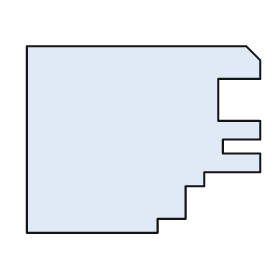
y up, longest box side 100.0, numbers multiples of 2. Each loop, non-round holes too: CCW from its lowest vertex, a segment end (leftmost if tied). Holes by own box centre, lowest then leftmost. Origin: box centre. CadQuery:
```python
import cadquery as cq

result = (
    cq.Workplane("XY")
    .moveTo(-50.0, -40.0)
    .lineTo(6.0, -40.0)
    .lineTo(6.0, -34.0)
    .lineTo(18.0, -34.0)
    .lineTo(18.0, -20.0)
    .lineTo(26.0, -20.0)
    .lineTo(26.0, -14.0)
    .lineTo(50.0, -14.0)
    .lineTo(50.0, -6.0)
    .lineTo(34.0, -6.0)
    .lineTo(34.0, 0.0)
    .lineTo(50.0, 0.0)
    .lineTo(50.0, 8.0)
    .lineTo(32.0, 8.0)
    .lineTo(32.0, 26.0)
    .lineTo(50.0, 26.0)
    .lineTo(50.0, 34.0)
    .lineTo(44.0, 40.0)
    .lineTo(-50.0, 40.0)
    .close()
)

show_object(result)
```